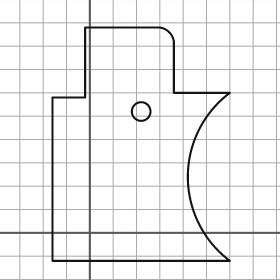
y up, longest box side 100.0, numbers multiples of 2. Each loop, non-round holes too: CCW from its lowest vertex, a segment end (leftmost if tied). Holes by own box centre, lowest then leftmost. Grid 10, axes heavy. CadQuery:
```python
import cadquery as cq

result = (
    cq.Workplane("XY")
    .moveTo(-16.0, -12.0)
    .lineTo(60.0, -12.0)
    .threePointArc((42.0, 24.0), (60.0, 60.0))
    .lineTo(36.0, 60.0)
    .lineTo(36.0, 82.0)
    .threePointArc((34.0, 86.0), (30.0, 88.0))
    .lineTo(-2.0, 88.0)
    .lineTo(-2.0, 58.0)
    .lineTo(-16.0, 58.0)
    .close()
    .moveTo(22.0, 52.0)
    .circle(4.0)
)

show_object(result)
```